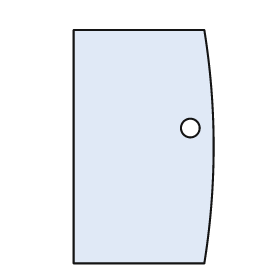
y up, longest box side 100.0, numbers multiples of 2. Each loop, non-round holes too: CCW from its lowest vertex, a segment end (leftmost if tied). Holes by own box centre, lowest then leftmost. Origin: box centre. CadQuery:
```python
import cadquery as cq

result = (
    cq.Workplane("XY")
    .moveTo(-30.0, -50.0)
    .lineTo(26.0, -50.0)
    .threePointArc((30.0, 0.0), (26.0, 50.0))
    .lineTo(-30.0, 50.0)
    .close()
    .moveTo(20.0, 8.0)
    .circle(4.0)
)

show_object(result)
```